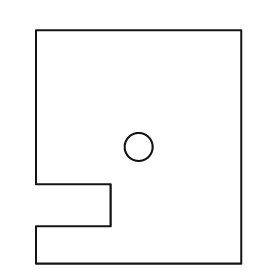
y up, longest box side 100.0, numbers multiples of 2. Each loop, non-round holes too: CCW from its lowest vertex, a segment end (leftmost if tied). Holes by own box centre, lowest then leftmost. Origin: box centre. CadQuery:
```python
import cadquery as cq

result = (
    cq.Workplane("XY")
    .moveTo(-44.0, -50.0)
    .lineTo(44.0, -50.0)
    .lineTo(44.0, 50.0)
    .lineTo(-44.0, 50.0)
    .lineTo(-44.0, -16.0)
    .lineTo(-12.0, -16.0)
    .lineTo(-12.0, -34.0)
    .lineTo(-44.0, -34.0)
    .close()
    .moveTo(0.0, 0.0)
    .circle(6.0)
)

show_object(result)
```